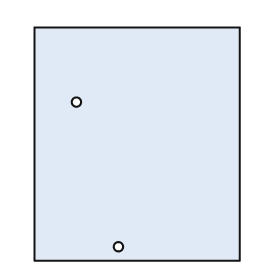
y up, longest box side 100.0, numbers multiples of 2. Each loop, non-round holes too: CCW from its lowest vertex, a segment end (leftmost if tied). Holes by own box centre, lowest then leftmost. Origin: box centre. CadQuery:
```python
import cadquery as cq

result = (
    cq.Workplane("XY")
    .moveTo(-44.0, -50.0)
    .lineTo(44.0, -50.0)
    .lineTo(44.0, 50.0)
    .lineTo(-44.0, 50.0)
    .close()
    .moveTo(-8.0, -44.0)
    .circle(2.0)
    .moveTo(-26.0, 18.0)
    .circle(2.0)
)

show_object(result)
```